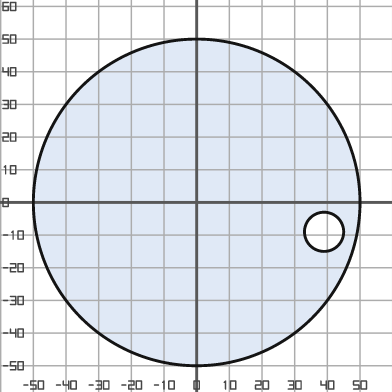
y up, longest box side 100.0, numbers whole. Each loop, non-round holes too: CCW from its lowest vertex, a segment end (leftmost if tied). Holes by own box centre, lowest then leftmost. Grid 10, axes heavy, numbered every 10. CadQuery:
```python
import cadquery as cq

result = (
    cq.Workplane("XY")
    .moveTo(0.0, 0.0)
    .circle(50.0)
    .moveTo(39.0, -9.0)
    .circle(6.0)
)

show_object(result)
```